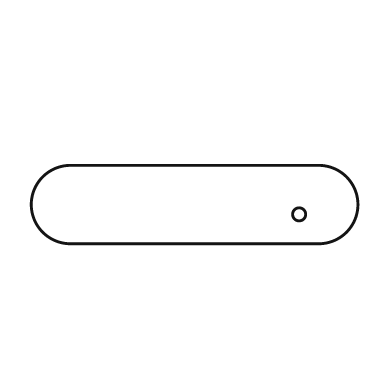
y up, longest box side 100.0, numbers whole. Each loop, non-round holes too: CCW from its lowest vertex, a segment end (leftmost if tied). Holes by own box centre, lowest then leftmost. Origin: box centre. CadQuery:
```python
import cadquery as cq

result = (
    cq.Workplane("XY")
    .moveTo(-38.0, -12.0)
    .lineTo(38.0, -12.0)
    .threePointArc((50.0, 0.0), (38.0, 12.0))
    .lineTo(-38.0, 12.0)
    .threePointArc((-50.0, 0.0), (-38.0, -12.0))
    .close()
    .moveTo(32.0, -3.0)
    .circle(2.0)
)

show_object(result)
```